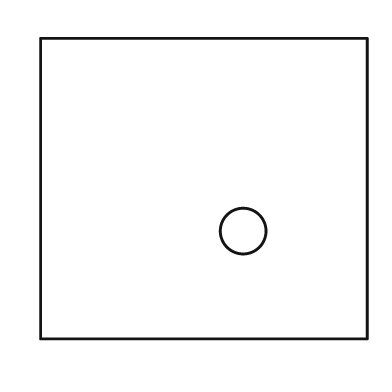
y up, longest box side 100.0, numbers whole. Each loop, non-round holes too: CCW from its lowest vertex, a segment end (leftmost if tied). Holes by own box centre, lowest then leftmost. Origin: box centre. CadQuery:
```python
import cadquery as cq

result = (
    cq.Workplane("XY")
    .moveTo(-50.0, -46.0)
    .lineTo(50.0, -46.0)
    .lineTo(50.0, 46.0)
    .lineTo(-50.0, 46.0)
    .close()
    .moveTo(12.0, -13.0)
    .circle(7.0)
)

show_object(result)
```